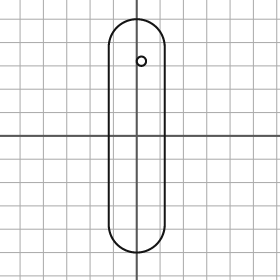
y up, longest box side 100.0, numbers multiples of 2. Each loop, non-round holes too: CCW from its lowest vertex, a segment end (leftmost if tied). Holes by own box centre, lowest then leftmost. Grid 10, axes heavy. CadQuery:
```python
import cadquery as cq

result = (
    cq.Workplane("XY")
    .moveTo(-12.0, -38.0)
    .threePointArc((0.0, -50.0), (12.0, -38.0))
    .lineTo(12.0, 38.0)
    .threePointArc((0.0, 50.0), (-12.0, 38.0))
    .close()
    .moveTo(2.0, 32.0)
    .circle(2.0)
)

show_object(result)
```